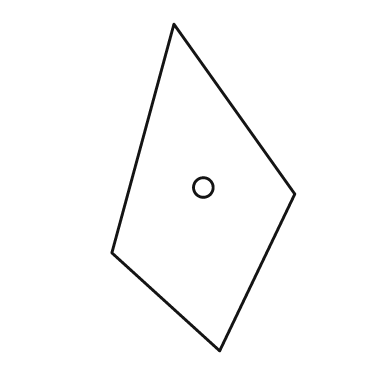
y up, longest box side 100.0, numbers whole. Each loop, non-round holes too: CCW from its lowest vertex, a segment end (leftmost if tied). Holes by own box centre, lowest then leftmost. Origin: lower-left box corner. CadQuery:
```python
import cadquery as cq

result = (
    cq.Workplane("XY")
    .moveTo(33.0, 0.0)
    .lineTo(56.0, 48.0)
    .lineTo(19.0, 100.0)
    .lineTo(0.0, 30.0)
    .close()
    .moveTo(28.0, 50.0)
    .circle(3.0)
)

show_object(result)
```